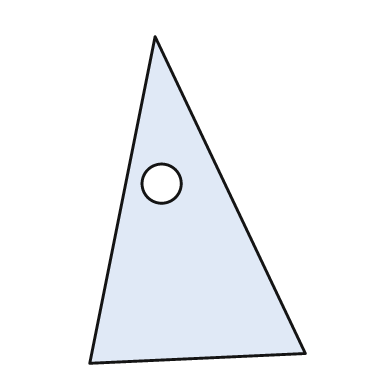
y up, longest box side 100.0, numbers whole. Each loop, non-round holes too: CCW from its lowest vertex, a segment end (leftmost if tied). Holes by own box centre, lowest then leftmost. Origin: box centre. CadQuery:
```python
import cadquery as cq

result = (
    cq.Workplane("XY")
    .moveTo(-33.0, -50.0)
    .lineTo(33.0, -47.0)
    .lineTo(-13.0, 50.0)
    .close()
    .moveTo(-11.0, 5.0)
    .circle(6.0)
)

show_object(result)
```